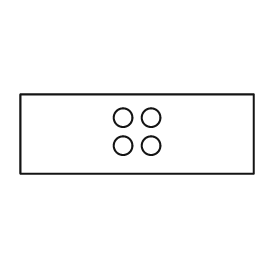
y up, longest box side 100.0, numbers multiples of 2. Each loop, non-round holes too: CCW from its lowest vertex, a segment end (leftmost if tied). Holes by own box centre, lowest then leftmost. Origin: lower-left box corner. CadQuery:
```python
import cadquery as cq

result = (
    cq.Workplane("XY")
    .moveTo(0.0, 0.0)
    .lineTo(100.0, 0.0)
    .lineTo(100.0, 34.0)
    .lineTo(0.0, 34.0)
    .close()
    .moveTo(44.0, 12.0)
    .circle(4.0)
    .moveTo(56.0, 12.0)
    .circle(4.0)
    .moveTo(44.0, 24.0)
    .circle(4.0)
    .moveTo(56.0, 24.0)
    .circle(4.0)
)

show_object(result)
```